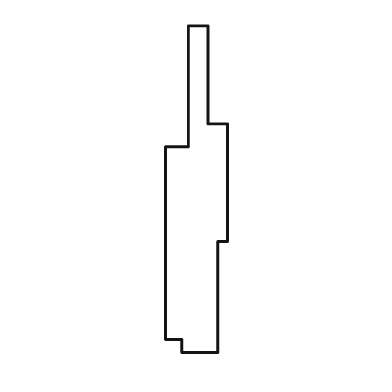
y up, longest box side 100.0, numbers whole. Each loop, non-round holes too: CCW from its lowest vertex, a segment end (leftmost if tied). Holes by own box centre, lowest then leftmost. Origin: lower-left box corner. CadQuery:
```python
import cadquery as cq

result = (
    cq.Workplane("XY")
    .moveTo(5.0, 0.0)
    .lineTo(16.0, 0.0)
    .lineTo(16.0, 34.0)
    .lineTo(19.0, 34.0)
    .lineTo(19.0, 70.0)
    .lineTo(13.0, 70.0)
    .lineTo(13.0, 100.0)
    .lineTo(7.0, 100.0)
    .lineTo(7.0, 63.0)
    .lineTo(0.0, 63.0)
    .lineTo(0.0, 4.0)
    .lineTo(5.0, 4.0)
    .close()
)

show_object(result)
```